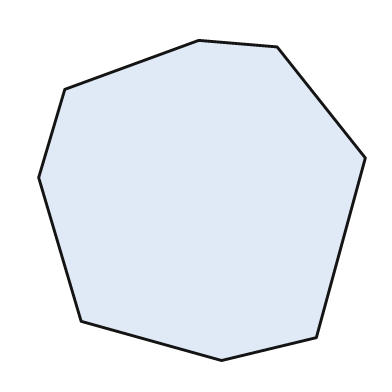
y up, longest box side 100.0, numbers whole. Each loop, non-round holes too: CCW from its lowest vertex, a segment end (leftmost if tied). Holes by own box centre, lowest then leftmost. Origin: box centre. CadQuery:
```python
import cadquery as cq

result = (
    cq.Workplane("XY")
    .moveTo(6.0, -49.0)
    .lineTo(35.0, -42.0)
    .lineTo(50.0, 13.0)
    .lineTo(23.0, 47.0)
    .lineTo(-1.0, 49.0)
    .lineTo(-42.0, 34.0)
    .lineTo(-50.0, 7.0)
    .lineTo(-37.0, -37.0)
    .close()
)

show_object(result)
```